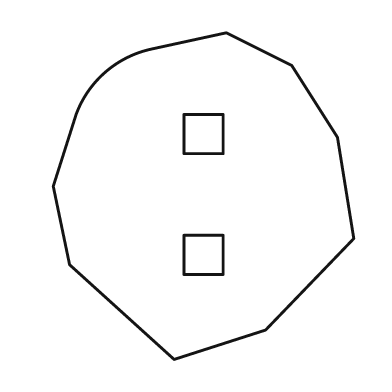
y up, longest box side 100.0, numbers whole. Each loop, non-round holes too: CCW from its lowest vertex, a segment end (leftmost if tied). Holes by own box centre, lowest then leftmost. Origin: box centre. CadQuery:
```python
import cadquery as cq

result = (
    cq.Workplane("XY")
    .moveTo(-9.0, -50.0)
    .lineTo(19.0, -41.0)
    .lineTo(46.0, -13.0)
    .lineTo(41.0, 18.0)
    .lineTo(27.0, 40.0)
    .lineTo(7.0, 50.0)
    .lineTo(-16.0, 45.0)
    .threePointArc((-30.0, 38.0), (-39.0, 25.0))
    .lineTo(-46.0, 3.0)
    .lineTo(-41.0, -21.0)
    .close()
    .moveTo(-6.0, -24.0)
    .lineTo(6.0, -24.0)
    .lineTo(6.0, -12.0)
    .lineTo(-6.0, -12.0)
    .close()
    .moveTo(-6.0, 13.0)
    .lineTo(6.0, 13.0)
    .lineTo(6.0, 25.0)
    .lineTo(-6.0, 25.0)
    .close()
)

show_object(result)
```